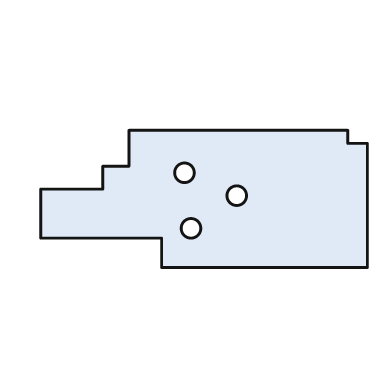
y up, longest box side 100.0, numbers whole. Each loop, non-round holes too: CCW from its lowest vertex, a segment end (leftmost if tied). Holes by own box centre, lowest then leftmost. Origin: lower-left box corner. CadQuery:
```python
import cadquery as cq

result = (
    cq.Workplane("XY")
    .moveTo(37.0, 0.0)
    .lineTo(100.0, 0.0)
    .lineTo(100.0, 38.0)
    .lineTo(94.0, 38.0)
    .lineTo(94.0, 42.0)
    .lineTo(27.0, 42.0)
    .lineTo(27.0, 31.0)
    .lineTo(19.0, 31.0)
    .lineTo(19.0, 24.0)
    .lineTo(0.0, 24.0)
    .lineTo(0.0, 9.0)
    .lineTo(37.0, 9.0)
    .close()
    .moveTo(46.0, 12.0)
    .circle(3.0)
    .moveTo(60.0, 22.0)
    .circle(3.0)
    .moveTo(44.0, 29.0)
    .circle(3.0)
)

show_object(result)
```